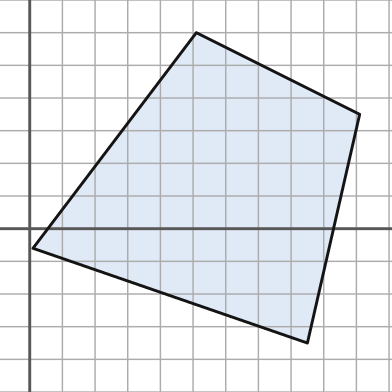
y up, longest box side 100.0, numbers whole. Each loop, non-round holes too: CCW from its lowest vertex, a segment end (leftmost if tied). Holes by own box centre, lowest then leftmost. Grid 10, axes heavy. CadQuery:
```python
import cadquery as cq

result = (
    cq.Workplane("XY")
    .moveTo(85.0, -35.0)
    .lineTo(101.0, 35.0)
    .lineTo(51.0, 60.0)
    .lineTo(1.0, -6.0)
    .close()
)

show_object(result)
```